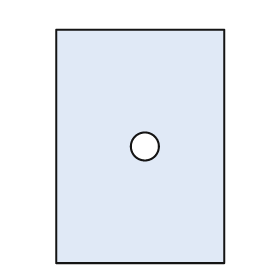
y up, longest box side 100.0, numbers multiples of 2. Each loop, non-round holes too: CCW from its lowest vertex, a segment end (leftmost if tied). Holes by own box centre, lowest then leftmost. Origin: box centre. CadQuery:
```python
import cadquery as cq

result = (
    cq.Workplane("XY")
    .moveTo(-36.0, -50.0)
    .lineTo(36.0, -50.0)
    .lineTo(36.0, 50.0)
    .lineTo(-36.0, 50.0)
    .close()
    .moveTo(2.0, 0.0)
    .circle(6.0)
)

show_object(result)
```